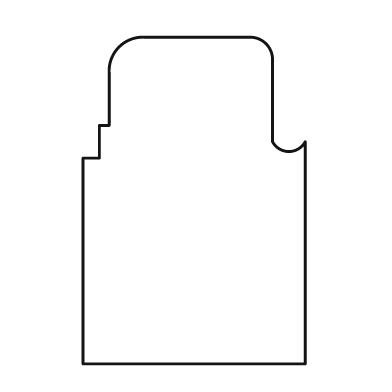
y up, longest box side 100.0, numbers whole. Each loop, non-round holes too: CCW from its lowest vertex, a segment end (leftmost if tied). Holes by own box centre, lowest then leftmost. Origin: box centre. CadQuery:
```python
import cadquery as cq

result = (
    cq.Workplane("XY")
    .moveTo(-34.0, -50.0)
    .lineTo(34.0, -50.0)
    .lineTo(34.0, 18.0)
    .threePointArc((29.0, 15.0), (24.0, 18.0))
    .lineTo(24.0, 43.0)
    .threePointArc((22.0, 48.0), (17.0, 50.0))
    .lineTo(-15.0, 50.0)
    .threePointArc((-23.0, 47.0), (-26.0, 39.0))
    .lineTo(-26.0, 23.0)
    .lineTo(-29.0, 23.0)
    .lineTo(-29.0, 13.0)
    .lineTo(-34.0, 13.0)
    .close()
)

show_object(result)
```